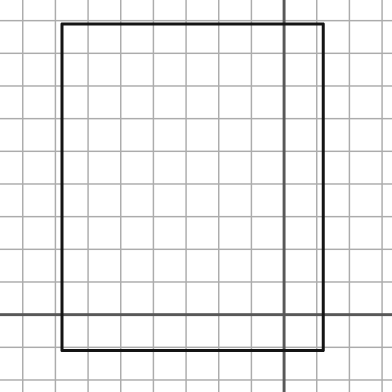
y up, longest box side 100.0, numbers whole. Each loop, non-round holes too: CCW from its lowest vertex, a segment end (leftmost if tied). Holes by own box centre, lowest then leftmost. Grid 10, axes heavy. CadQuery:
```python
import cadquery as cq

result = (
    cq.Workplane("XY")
    .moveTo(-68.0, -11.0)
    .lineTo(12.0, -11.0)
    .lineTo(12.0, 89.0)
    .lineTo(-68.0, 89.0)
    .close()
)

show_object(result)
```